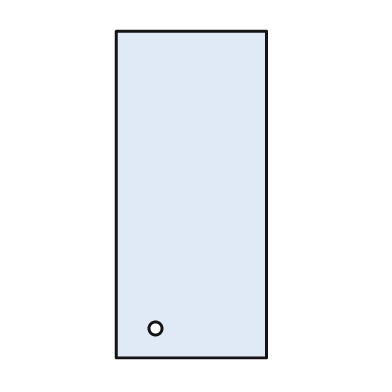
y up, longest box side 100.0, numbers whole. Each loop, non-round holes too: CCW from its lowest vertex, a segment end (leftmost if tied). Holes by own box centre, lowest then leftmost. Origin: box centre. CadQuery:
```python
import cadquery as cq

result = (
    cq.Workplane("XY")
    .moveTo(-23.0, -50.0)
    .lineTo(23.0, -50.0)
    .lineTo(23.0, 50.0)
    .lineTo(-23.0, 50.0)
    .close()
    .moveTo(-11.0, -41.0)
    .circle(2.0)
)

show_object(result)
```